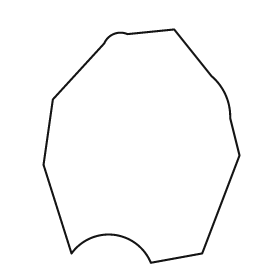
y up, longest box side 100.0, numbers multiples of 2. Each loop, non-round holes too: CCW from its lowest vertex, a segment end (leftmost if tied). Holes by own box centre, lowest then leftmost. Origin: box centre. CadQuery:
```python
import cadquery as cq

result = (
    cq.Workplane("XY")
    .moveTo(4.0, -50.0)
    .lineTo(26.0, -46.0)
    .lineTo(42.0, -4.0)
    .lineTo(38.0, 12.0)
    .threePointArc((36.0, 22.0), (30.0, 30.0))
    .lineTo(14.0, 50.0)
    .lineTo(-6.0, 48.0)
    .threePointArc((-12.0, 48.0), (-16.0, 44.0))
    .lineTo(-38.0, 20.0)
    .lineTo(-42.0, -8.0)
    .lineTo(-30.0, -46.0)
    .threePointArc((-12.0, -38.0), (4.0, -50.0))
    .close()
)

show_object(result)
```